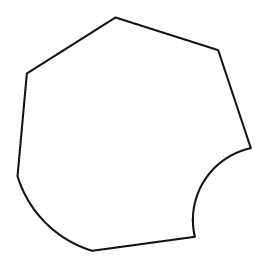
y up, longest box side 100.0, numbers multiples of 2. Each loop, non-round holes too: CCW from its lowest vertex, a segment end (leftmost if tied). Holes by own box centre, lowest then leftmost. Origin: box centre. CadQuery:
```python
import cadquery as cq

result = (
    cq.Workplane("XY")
    .moveTo(-18.0, -50.0)
    .lineTo(26.0, -44.0)
    .threePointArc((30.0, -20.0), (50.0, -6.0))
    .lineTo(36.0, 36.0)
    .lineTo(-8.0, 50.0)
    .lineTo(-46.0, 26.0)
    .lineTo(-50.0, -18.0)
    .threePointArc((-38.0, -38.0), (-18.0, -50.0))
    .close()
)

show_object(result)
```